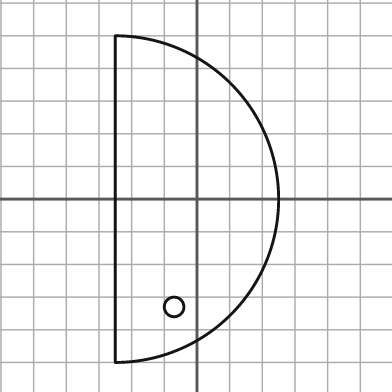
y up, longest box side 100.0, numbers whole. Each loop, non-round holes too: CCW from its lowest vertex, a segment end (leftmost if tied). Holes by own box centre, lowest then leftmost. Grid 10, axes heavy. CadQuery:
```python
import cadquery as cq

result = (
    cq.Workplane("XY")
    .moveTo(-25.0, -50.0)
    .threePointArc((25.0, 0.0), (-25.0, 50.0))
    .close()
    .moveTo(-7.0, -33.0)
    .circle(3.0)
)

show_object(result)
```